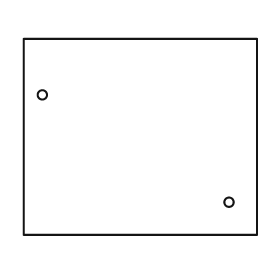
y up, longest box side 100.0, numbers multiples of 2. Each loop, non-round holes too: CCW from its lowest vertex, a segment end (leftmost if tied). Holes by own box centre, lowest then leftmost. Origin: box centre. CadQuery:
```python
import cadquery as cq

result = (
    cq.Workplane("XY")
    .moveTo(-50.0, -42.0)
    .lineTo(50.0, -42.0)
    .lineTo(50.0, 42.0)
    .lineTo(-50.0, 42.0)
    .close()
    .moveTo(38.0, -28.0)
    .circle(2.0)
    .moveTo(-42.0, 18.0)
    .circle(2.0)
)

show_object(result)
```